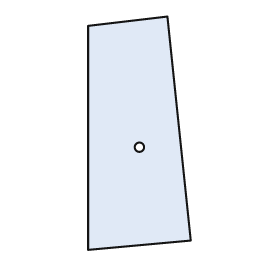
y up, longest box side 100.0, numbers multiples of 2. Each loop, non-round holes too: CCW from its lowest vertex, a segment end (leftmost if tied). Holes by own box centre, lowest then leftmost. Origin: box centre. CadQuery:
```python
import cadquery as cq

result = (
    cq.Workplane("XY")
    .moveTo(-22.0, -50.0)
    .lineTo(22.0, -46.0)
    .lineTo(12.0, 50.0)
    .lineTo(-22.0, 46.0)
    .close()
    .moveTo(0.0, -6.0)
    .circle(2.0)
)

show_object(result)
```